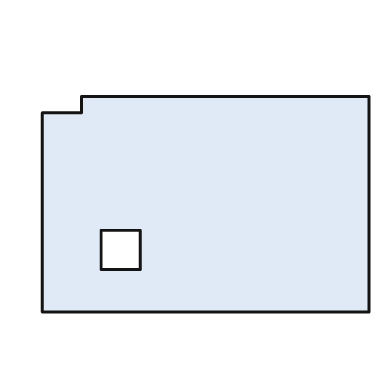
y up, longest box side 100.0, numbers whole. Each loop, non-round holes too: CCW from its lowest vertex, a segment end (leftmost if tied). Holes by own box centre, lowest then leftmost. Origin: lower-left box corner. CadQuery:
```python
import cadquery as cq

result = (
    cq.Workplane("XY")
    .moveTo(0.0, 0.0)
    .lineTo(100.0, 0.0)
    .lineTo(100.0, 66.0)
    .lineTo(12.0, 66.0)
    .lineTo(12.0, 61.0)
    .lineTo(0.0, 61.0)
    .close()
    .moveTo(18.0, 13.0)
    .lineTo(30.0, 13.0)
    .lineTo(30.0, 25.0)
    .lineTo(18.0, 25.0)
    .close()
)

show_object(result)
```